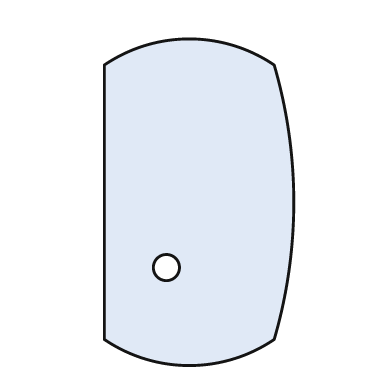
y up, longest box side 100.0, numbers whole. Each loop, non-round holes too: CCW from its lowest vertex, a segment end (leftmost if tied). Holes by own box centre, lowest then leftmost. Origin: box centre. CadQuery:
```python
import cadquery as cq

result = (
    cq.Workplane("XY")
    .moveTo(-29.0, -42.0)
    .threePointArc((-3.0, -50.0), (23.0, -42.0))
    .threePointArc((29.0, 0.0), (23.0, 42.0))
    .threePointArc((-3.0, 50.0), (-29.0, 42.0))
    .close()
    .moveTo(-10.0, -20.0)
    .circle(4.0)
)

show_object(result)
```